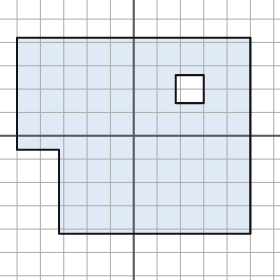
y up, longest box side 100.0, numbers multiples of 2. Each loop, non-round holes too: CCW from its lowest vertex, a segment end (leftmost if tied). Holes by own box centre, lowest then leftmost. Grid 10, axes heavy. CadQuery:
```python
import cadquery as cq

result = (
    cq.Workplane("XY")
    .moveTo(-32.0, -42.0)
    .lineTo(50.0, -42.0)
    .lineTo(50.0, 42.0)
    .lineTo(-50.0, 42.0)
    .lineTo(-50.0, -6.0)
    .lineTo(-32.0, -6.0)
    .close()
    .moveTo(18.0, 14.0)
    .lineTo(30.0, 14.0)
    .lineTo(30.0, 26.0)
    .lineTo(18.0, 26.0)
    .close()
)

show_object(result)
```